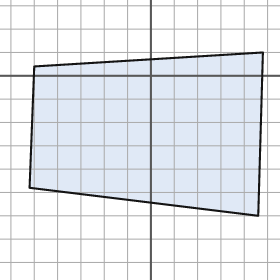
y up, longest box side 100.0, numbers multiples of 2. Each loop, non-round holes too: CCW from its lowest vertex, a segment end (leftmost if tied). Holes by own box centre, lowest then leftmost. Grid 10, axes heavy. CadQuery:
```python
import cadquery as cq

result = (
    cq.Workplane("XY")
    .moveTo(46.0, -60.0)
    .lineTo(48.0, 10.0)
    .lineTo(-50.0, 4.0)
    .lineTo(-52.0, -48.0)
    .close()
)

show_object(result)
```